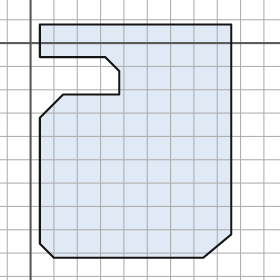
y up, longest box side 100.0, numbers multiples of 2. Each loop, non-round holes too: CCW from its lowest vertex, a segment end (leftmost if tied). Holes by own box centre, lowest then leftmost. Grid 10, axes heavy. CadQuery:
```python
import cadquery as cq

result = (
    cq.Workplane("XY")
    .moveTo(10.0, -92.0)
    .lineTo(74.0, -92.0)
    .lineTo(86.0, -82.0)
    .lineTo(86.0, 8.0)
    .lineTo(4.0, 8.0)
    .lineTo(4.0, -6.0)
    .lineTo(32.0, -6.0)
    .lineTo(38.0, -12.0)
    .lineTo(38.0, -22.0)
    .lineTo(14.0, -22.0)
    .lineTo(4.0, -32.0)
    .lineTo(4.0, -86.0)
    .close()
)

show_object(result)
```